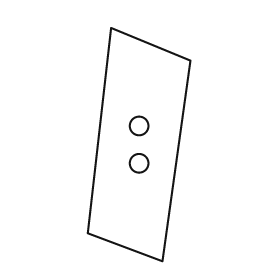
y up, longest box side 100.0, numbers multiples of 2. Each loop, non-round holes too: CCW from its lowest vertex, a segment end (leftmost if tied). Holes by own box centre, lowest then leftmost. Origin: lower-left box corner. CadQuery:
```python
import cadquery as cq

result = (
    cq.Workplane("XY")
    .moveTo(32.0, 0.0)
    .lineTo(44.0, 86.0)
    .lineTo(10.0, 100.0)
    .lineTo(0.0, 12.0)
    .close()
    .moveTo(22.0, 42.0)
    .circle(4.0)
    .moveTo(22.0, 58.0)
    .circle(4.0)
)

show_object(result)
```